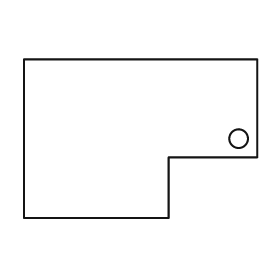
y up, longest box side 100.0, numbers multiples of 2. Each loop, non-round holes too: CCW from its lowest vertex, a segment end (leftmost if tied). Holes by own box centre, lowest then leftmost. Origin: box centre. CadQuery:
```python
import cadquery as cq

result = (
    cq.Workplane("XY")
    .moveTo(-50.0, -34.0)
    .lineTo(12.0, -34.0)
    .lineTo(12.0, -8.0)
    .lineTo(50.0, -8.0)
    .lineTo(50.0, 34.0)
    .lineTo(-50.0, 34.0)
    .close()
    .moveTo(42.0, 0.0)
    .circle(4.0)
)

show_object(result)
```